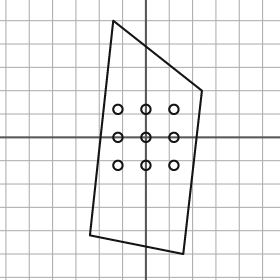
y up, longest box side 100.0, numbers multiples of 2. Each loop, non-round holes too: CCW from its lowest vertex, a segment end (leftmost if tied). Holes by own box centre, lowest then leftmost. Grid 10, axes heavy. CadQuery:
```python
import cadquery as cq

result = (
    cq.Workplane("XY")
    .moveTo(16.0, -50.0)
    .lineTo(24.0, 20.0)
    .lineTo(-14.0, 50.0)
    .lineTo(-24.0, -42.0)
    .close()
    .moveTo(-12.0, -12.0)
    .circle(2.0)
    .moveTo(0.0, -12.0)
    .circle(2.0)
    .moveTo(12.0, -12.0)
    .circle(2.0)
    .moveTo(-12.0, 0.0)
    .circle(2.0)
    .moveTo(0.0, 0.0)
    .circle(2.0)
    .moveTo(12.0, 0.0)
    .circle(2.0)
    .moveTo(-12.0, 12.0)
    .circle(2.0)
    .moveTo(0.0, 12.0)
    .circle(2.0)
    .moveTo(12.0, 12.0)
    .circle(2.0)
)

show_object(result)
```